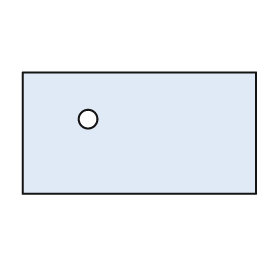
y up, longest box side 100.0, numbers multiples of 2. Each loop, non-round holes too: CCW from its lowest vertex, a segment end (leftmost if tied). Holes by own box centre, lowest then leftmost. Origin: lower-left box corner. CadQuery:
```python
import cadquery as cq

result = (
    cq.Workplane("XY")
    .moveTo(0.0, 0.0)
    .lineTo(100.0, 0.0)
    .lineTo(100.0, 52.0)
    .lineTo(0.0, 52.0)
    .close()
    .moveTo(28.0, 32.0)
    .circle(4.0)
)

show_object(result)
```